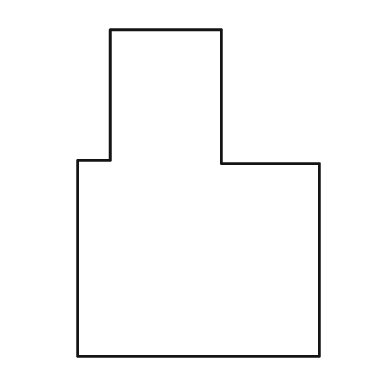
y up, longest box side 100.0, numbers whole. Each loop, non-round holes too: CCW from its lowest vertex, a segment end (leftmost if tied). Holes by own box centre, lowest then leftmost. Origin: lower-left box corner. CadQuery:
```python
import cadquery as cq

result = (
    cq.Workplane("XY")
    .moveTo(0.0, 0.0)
    .lineTo(74.0, 0.0)
    .lineTo(74.0, 59.0)
    .lineTo(44.0, 59.0)
    .lineTo(44.0, 100.0)
    .lineTo(10.0, 100.0)
    .lineTo(10.0, 60.0)
    .lineTo(0.0, 60.0)
    .close()
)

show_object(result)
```